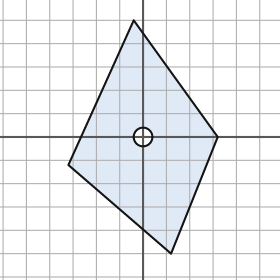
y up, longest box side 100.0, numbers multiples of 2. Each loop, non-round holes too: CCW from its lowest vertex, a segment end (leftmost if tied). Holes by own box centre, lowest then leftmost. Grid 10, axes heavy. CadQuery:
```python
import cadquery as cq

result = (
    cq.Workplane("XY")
    .moveTo(12.0, -50.0)
    .lineTo(32.0, 0.0)
    .lineTo(-4.0, 50.0)
    .lineTo(-32.0, -12.0)
    .close()
    .moveTo(0.0, 0.0)
    .circle(4.0)
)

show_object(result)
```